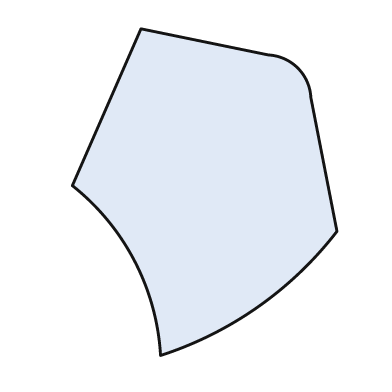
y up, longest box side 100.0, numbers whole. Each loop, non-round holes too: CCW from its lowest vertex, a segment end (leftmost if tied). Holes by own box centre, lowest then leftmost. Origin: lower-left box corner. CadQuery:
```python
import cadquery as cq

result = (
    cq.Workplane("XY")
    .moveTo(27.0, 0.0)
    .threePointArc((57.0, 15.0), (81.0, 38.0))
    .lineTo(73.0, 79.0)
    .threePointArc((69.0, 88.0), (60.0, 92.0))
    .lineTo(21.0, 100.0)
    .lineTo(0.0, 52.0)
    .threePointArc((19.0, 29.0), (27.0, 0.0))
    .close()
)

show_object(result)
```